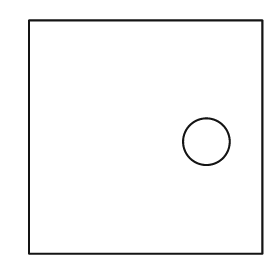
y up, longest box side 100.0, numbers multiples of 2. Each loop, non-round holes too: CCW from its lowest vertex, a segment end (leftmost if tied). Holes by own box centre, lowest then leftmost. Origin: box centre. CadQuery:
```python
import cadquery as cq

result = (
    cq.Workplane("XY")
    .moveTo(-50.0, -50.0)
    .lineTo(50.0, -50.0)
    .lineTo(50.0, 50.0)
    .lineTo(-50.0, 50.0)
    .close()
    .moveTo(26.0, -2.0)
    .circle(10.0)
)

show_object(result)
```